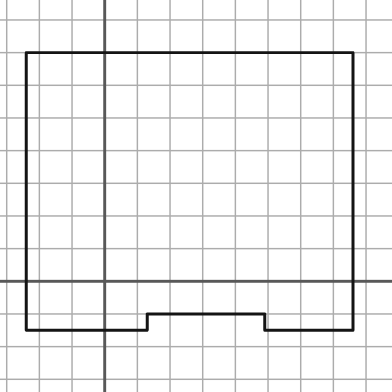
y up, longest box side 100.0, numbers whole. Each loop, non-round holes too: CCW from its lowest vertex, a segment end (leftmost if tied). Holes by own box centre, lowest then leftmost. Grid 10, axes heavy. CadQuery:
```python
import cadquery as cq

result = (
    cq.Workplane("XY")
    .moveTo(-24.0, -15.0)
    .lineTo(13.0, -15.0)
    .lineTo(13.0, -10.0)
    .lineTo(49.0, -10.0)
    .lineTo(49.0, -15.0)
    .lineTo(76.0, -15.0)
    .lineTo(76.0, 70.0)
    .lineTo(-24.0, 70.0)
    .close()
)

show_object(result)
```